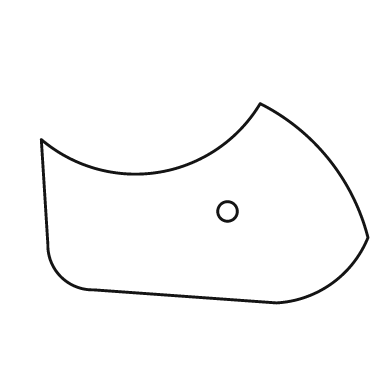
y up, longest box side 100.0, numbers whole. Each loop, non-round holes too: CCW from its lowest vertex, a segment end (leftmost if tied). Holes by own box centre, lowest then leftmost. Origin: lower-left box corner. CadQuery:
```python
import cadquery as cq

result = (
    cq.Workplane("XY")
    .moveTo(72.0, 0.0)
    .threePointArc((89.0, 6.0), (100.0, 20.0))
    .threePointArc((88.0, 44.0), (67.0, 61.0))
    .threePointArc((36.0, 40.0), (0.0, 50.0))
    .lineTo(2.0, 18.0)
    .threePointArc((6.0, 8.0), (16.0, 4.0))
    .close()
    .moveTo(57.0, 28.0)
    .circle(3.0)
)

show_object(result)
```